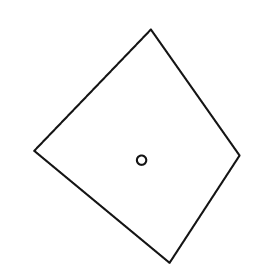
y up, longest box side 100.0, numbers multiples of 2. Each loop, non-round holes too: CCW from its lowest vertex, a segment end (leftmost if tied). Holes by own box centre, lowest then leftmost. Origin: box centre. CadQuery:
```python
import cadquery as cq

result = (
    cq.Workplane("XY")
    .moveTo(14.0, -50.0)
    .lineTo(44.0, -4.0)
    .lineTo(6.0, 50.0)
    .lineTo(-44.0, -2.0)
    .close()
    .moveTo(2.0, -6.0)
    .circle(2.0)
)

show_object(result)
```